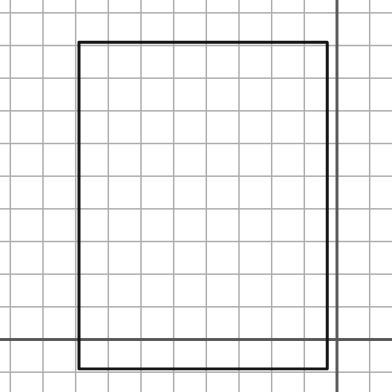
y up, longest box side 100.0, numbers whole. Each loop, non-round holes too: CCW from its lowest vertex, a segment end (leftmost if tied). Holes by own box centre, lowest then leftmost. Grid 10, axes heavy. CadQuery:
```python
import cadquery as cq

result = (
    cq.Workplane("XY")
    .moveTo(-79.0, -9.0)
    .lineTo(-3.0, -9.0)
    .lineTo(-3.0, 91.0)
    .lineTo(-79.0, 91.0)
    .close()
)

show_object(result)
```